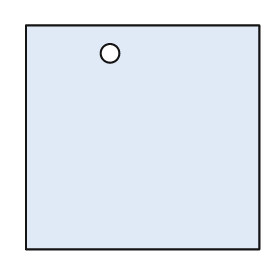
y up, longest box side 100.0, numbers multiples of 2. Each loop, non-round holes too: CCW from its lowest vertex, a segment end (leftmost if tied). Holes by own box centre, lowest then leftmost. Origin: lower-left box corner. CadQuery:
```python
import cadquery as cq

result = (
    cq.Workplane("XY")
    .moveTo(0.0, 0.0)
    .lineTo(100.0, 0.0)
    .lineTo(100.0, 96.0)
    .lineTo(0.0, 96.0)
    .close()
    .moveTo(36.0, 84.0)
    .circle(4.0)
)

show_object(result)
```